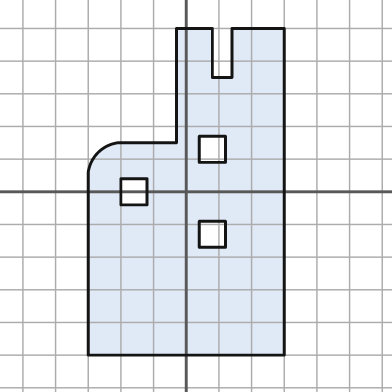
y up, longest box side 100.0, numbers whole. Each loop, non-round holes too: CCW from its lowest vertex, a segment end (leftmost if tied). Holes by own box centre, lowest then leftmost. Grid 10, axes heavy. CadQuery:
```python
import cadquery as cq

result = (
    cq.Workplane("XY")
    .moveTo(-30.0, -50.0)
    .lineTo(30.0, -50.0)
    .lineTo(30.0, 50.0)
    .lineTo(14.0, 50.0)
    .lineTo(14.0, 35.0)
    .lineTo(8.0, 35.0)
    .lineTo(8.0, 50.0)
    .lineTo(-3.0, 50.0)
    .lineTo(-3.0, 15.0)
    .lineTo(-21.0, 15.0)
    .threePointArc((-27.0, 12.0), (-30.0, 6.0))
    .close()
    .moveTo(4.0, -17.0)
    .lineTo(12.0, -17.0)
    .lineTo(12.0, -9.0)
    .lineTo(4.0, -9.0)
    .close()
    .moveTo(-20.0, -4.0)
    .lineTo(-12.0, -4.0)
    .lineTo(-12.0, 4.0)
    .lineTo(-20.0, 4.0)
    .close()
    .moveTo(4.0, 9.0)
    .lineTo(12.0, 9.0)
    .lineTo(12.0, 17.0)
    .lineTo(4.0, 17.0)
    .close()
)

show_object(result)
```